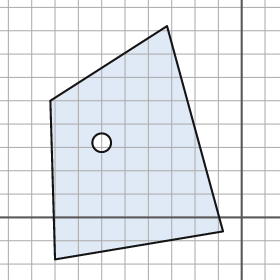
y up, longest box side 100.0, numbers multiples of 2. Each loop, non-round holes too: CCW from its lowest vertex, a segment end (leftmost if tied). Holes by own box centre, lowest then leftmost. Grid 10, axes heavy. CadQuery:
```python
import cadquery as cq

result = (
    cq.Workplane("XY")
    .moveTo(-80.0, -18.0)
    .lineTo(-8.0, -6.0)
    .lineTo(-32.0, 82.0)
    .lineTo(-82.0, 50.0)
    .close()
    .moveTo(-60.0, 32.0)
    .circle(4.0)
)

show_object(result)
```